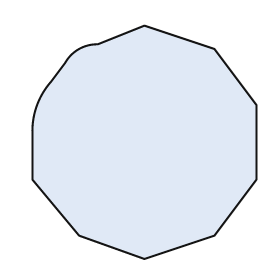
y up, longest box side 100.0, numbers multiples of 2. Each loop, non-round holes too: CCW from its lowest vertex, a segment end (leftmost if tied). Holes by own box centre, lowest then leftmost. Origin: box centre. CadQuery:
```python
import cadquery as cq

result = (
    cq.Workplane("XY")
    .moveTo(0.0, -50.0)
    .lineTo(30.0, -40.0)
    .lineTo(48.0, -16.0)
    .lineTo(48.0, 16.0)
    .lineTo(30.0, 40.0)
    .lineTo(0.0, 50.0)
    .lineTo(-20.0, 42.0)
    .threePointArc((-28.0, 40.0), (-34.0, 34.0))
    .lineTo(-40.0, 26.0)
    .threePointArc((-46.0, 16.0), (-48.0, 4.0))
    .lineTo(-48.0, -16.0)
    .lineTo(-28.0, -40.0)
    .close()
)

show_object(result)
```